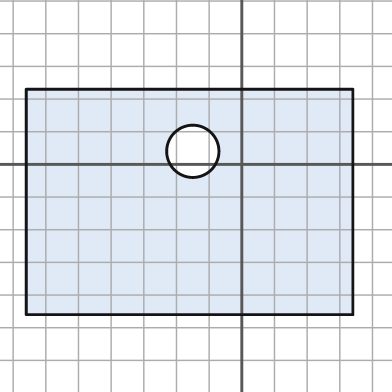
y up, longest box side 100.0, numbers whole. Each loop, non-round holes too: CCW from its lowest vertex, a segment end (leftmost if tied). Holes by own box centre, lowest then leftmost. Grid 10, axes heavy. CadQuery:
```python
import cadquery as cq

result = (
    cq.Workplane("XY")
    .moveTo(-66.0, -46.0)
    .lineTo(34.0, -46.0)
    .lineTo(34.0, 23.0)
    .lineTo(-66.0, 23.0)
    .close()
    .moveTo(-15.0, 4.0)
    .circle(8.0)
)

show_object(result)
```